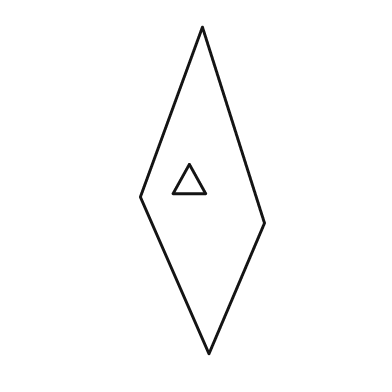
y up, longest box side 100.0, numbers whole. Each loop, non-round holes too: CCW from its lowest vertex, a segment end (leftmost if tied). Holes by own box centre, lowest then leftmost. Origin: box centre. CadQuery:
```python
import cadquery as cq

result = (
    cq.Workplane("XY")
    .moveTo(2.0, -50.0)
    .lineTo(19.0, -10.0)
    .lineTo(0.0, 50.0)
    .lineTo(-19.0, -2.0)
    .close()
    .moveTo(-9.0, -1.0)
    .lineTo(1.0, -1.0)
    .lineTo(-4.0, 8.0)
    .close()
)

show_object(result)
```